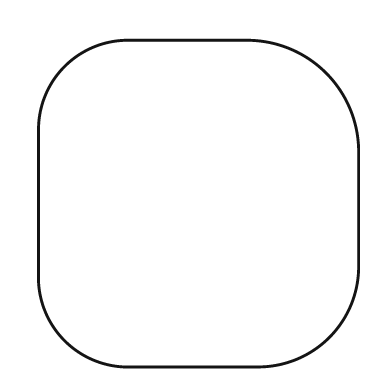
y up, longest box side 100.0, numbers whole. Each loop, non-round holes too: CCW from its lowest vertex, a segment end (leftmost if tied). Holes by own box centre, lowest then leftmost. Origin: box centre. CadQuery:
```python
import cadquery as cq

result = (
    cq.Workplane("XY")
    .moveTo(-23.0, -50.0)
    .lineTo(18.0, -50.0)
    .threePointArc((40.0, -41.0), (49.0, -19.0))
    .lineTo(49.0, 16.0)
    .threePointArc((39.0, 40.0), (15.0, 50.0))
    .lineTo(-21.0, 50.0)
    .threePointArc((-41.0, 42.0), (-49.0, 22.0))
    .lineTo(-49.0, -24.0)
    .threePointArc((-41.0, -42.0), (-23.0, -50.0))
    .close()
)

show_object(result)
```